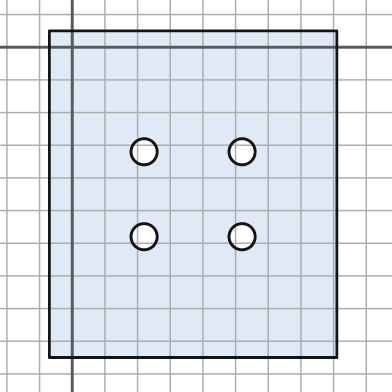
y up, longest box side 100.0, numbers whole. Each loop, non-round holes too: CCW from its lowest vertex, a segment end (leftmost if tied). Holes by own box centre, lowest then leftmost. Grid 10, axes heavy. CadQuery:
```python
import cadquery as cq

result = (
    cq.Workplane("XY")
    .moveTo(-7.0, -95.0)
    .lineTo(81.0, -95.0)
    .lineTo(81.0, 5.0)
    .lineTo(-7.0, 5.0)
    .close()
    .moveTo(22.0, -58.0)
    .circle(4.0)
    .moveTo(52.0, -58.0)
    .circle(4.0)
    .moveTo(22.0, -32.0)
    .circle(4.0)
    .moveTo(52.0, -32.0)
    .circle(4.0)
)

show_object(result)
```